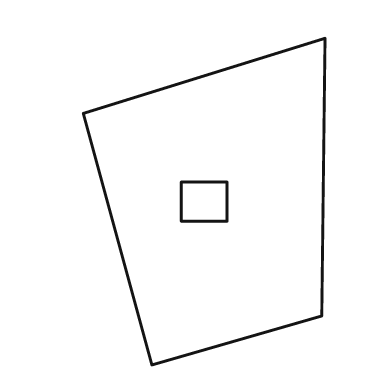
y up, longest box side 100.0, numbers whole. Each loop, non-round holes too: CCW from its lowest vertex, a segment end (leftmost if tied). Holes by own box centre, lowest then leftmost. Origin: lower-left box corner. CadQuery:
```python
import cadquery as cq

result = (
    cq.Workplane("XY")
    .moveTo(21.0, 0.0)
    .lineTo(73.0, 15.0)
    .lineTo(74.0, 100.0)
    .lineTo(0.0, 77.0)
    .close()
    .moveTo(30.0, 44.0)
    .lineTo(44.0, 44.0)
    .lineTo(44.0, 56.0)
    .lineTo(30.0, 56.0)
    .close()
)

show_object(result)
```